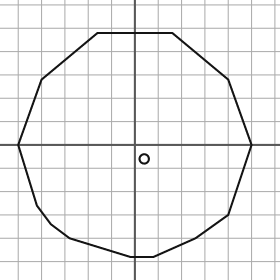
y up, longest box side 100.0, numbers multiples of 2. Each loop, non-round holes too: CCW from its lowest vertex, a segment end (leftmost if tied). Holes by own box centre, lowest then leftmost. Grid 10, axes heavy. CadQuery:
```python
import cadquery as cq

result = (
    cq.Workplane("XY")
    .moveTo(-2.0, -48.0)
    .lineTo(8.0, -48.0)
    .lineTo(26.0, -40.0)
    .lineTo(40.0, -30.0)
    .lineTo(50.0, 0.0)
    .lineTo(40.0, 28.0)
    .lineTo(16.0, 48.0)
    .lineTo(-16.0, 48.0)
    .lineTo(-40.0, 28.0)
    .lineTo(-50.0, 0.0)
    .lineTo(-42.0, -26.0)
    .lineTo(-36.0, -34.0)
    .lineTo(-28.0, -40.0)
    .close()
    .moveTo(4.0, -6.0)
    .circle(2.0)
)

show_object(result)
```